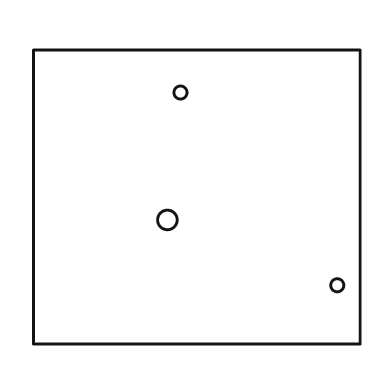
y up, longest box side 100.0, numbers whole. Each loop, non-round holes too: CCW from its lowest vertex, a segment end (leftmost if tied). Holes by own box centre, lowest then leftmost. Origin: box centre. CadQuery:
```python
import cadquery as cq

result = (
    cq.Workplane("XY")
    .moveTo(-50.0, -45.0)
    .lineTo(50.0, -45.0)
    .lineTo(50.0, 45.0)
    .lineTo(-50.0, 45.0)
    .close()
    .moveTo(43.0, -27.0)
    .circle(2.0)
    .moveTo(-9.0, -7.0)
    .circle(3.0)
    .moveTo(-5.0, 32.0)
    .circle(2.0)
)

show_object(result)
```